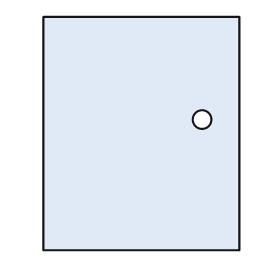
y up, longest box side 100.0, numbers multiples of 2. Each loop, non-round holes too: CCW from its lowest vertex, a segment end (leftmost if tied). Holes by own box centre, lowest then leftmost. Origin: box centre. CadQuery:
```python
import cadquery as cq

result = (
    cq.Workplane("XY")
    .moveTo(-42.0, -50.0)
    .lineTo(42.0, -50.0)
    .lineTo(42.0, 50.0)
    .lineTo(-42.0, 50.0)
    .close()
    .moveTo(26.0, 6.0)
    .circle(4.0)
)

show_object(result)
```